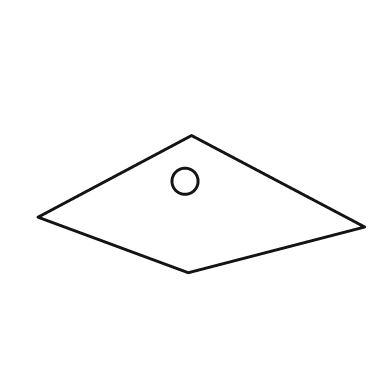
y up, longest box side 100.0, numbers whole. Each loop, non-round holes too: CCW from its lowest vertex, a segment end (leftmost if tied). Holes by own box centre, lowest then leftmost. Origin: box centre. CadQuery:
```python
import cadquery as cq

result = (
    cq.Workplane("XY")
    .moveTo(-4.0, -21.0)
    .lineTo(50.0, -7.0)
    .lineTo(-3.0, 21.0)
    .lineTo(-50.0, -4.0)
    .close()
    .moveTo(-5.0, 7.0)
    .circle(4.0)
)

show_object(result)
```